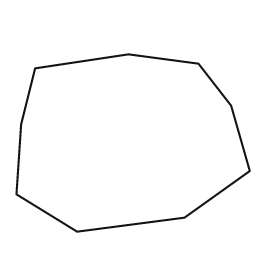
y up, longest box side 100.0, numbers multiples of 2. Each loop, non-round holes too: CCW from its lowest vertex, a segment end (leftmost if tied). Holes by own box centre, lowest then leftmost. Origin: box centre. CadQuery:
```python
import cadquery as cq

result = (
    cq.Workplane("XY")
    .moveTo(-24.0, -38.0)
    .lineTo(22.0, -32.0)
    .lineTo(50.0, -12.0)
    .lineTo(42.0, 16.0)
    .lineTo(28.0, 34.0)
    .lineTo(-2.0, 38.0)
    .lineTo(-42.0, 32.0)
    .lineTo(-48.0, 8.0)
    .lineTo(-50.0, -22.0)
    .close()
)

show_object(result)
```